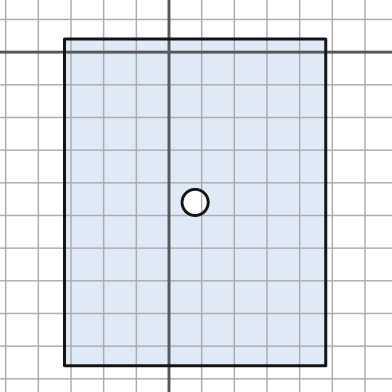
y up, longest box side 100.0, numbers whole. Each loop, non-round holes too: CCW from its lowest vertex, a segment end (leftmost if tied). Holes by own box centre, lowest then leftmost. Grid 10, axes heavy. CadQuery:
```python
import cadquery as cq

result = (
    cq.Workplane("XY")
    .moveTo(-32.0, -96.0)
    .lineTo(48.0, -96.0)
    .lineTo(48.0, 4.0)
    .lineTo(-32.0, 4.0)
    .close()
    .moveTo(8.0, -46.0)
    .circle(4.0)
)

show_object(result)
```